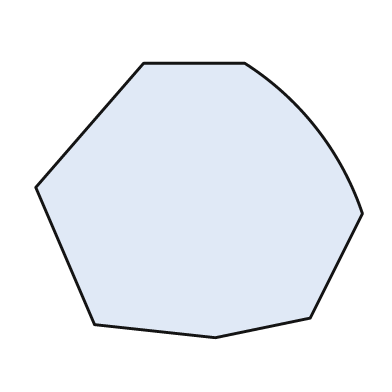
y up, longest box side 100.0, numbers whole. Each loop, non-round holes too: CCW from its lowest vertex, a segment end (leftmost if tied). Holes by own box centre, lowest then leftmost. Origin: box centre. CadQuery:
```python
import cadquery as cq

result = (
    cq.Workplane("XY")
    .moveTo(5.0, -42.0)
    .lineTo(34.0, -36.0)
    .lineTo(50.0, -4.0)
    .threePointArc((36.0, 22.0), (14.0, 42.0))
    .lineTo(-17.0, 42.0)
    .lineTo(-50.0, 4.0)
    .lineTo(-32.0, -38.0)
    .close()
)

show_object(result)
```